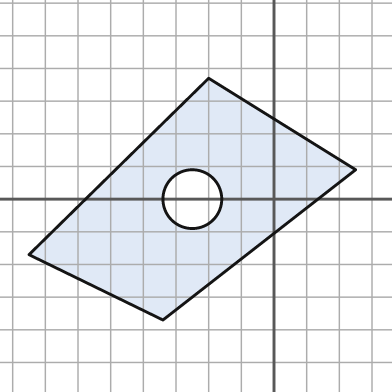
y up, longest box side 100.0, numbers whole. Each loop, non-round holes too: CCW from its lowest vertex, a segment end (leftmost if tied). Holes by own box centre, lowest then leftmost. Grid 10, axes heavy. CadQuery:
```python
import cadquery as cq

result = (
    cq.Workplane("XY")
    .moveTo(-34.0, -37.0)
    .lineTo(25.0, 9.0)
    .lineTo(-20.0, 37.0)
    .lineTo(-75.0, -17.0)
    .close()
    .moveTo(-25.0, 0.0)
    .circle(9.0)
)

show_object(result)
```